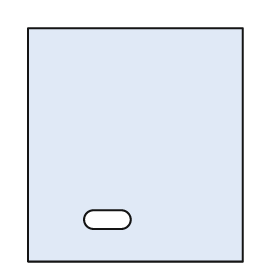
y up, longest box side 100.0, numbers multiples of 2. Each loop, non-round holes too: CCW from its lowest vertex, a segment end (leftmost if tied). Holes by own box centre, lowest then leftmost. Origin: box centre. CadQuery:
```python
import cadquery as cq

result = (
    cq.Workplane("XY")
    .moveTo(-46.0, -50.0)
    .lineTo(46.0, -50.0)
    .lineTo(46.0, 50.0)
    .lineTo(-46.0, 50.0)
    .close()
    .moveTo(-18.0, -36.0)
    .lineTo(-6.0, -36.0)
    .threePointArc((-2.0, -32.0), (-6.0, -28.0))
    .lineTo(-18.0, -28.0)
    .threePointArc((-22.0, -32.0), (-18.0, -36.0))
    .close()
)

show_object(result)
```